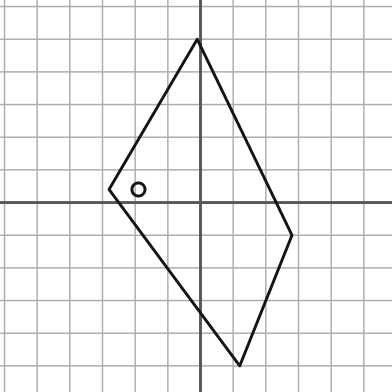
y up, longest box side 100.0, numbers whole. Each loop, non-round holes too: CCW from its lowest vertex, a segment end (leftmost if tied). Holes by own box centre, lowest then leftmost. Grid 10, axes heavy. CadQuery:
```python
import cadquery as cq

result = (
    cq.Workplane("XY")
    .moveTo(12.0, -50.0)
    .lineTo(28.0, -10.0)
    .lineTo(-1.0, 50.0)
    .lineTo(-28.0, 4.0)
    .close()
    .moveTo(-19.0, 4.0)
    .circle(2.0)
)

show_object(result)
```